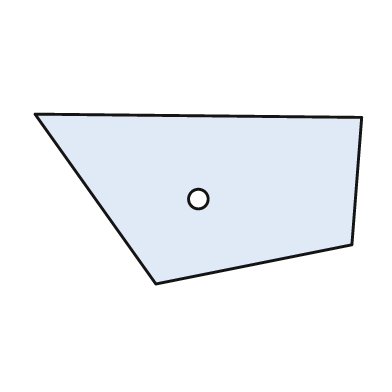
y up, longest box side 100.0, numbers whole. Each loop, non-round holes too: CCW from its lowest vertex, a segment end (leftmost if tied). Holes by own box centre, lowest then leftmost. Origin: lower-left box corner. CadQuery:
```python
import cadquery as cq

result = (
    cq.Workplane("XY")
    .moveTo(37.0, 0.0)
    .lineTo(97.0, 12.0)
    .lineTo(100.0, 51.0)
    .lineTo(0.0, 52.0)
    .close()
    .moveTo(50.0, 26.0)
    .circle(3.0)
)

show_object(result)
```